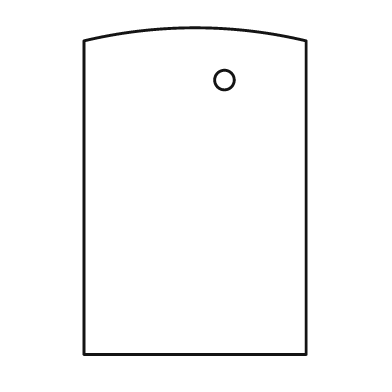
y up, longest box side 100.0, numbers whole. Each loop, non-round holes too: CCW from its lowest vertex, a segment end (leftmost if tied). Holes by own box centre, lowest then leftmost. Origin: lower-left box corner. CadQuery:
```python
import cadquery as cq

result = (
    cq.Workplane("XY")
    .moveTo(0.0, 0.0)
    .lineTo(68.0, 0.0)
    .lineTo(68.0, 96.0)
    .threePointArc((34.0, 100.0), (0.0, 96.0))
    .close()
    .moveTo(43.0, 84.0)
    .circle(3.0)
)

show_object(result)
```